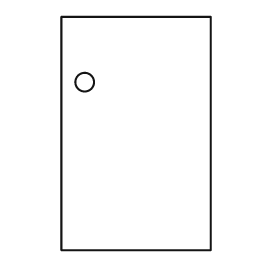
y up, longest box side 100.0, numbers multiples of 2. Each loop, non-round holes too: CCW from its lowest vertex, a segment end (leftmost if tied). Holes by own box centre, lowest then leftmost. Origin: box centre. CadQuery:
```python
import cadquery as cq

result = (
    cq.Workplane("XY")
    .moveTo(-32.0, -50.0)
    .lineTo(32.0, -50.0)
    .lineTo(32.0, 50.0)
    .lineTo(-32.0, 50.0)
    .close()
    .moveTo(-22.0, 22.0)
    .circle(4.0)
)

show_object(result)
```